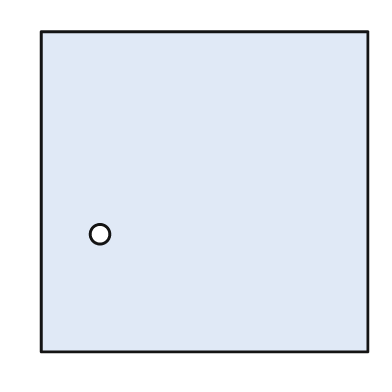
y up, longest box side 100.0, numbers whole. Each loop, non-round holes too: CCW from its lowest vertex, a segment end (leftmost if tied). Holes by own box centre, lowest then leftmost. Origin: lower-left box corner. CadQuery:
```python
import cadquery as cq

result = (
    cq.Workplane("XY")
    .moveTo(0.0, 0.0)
    .lineTo(100.0, 0.0)
    .lineTo(100.0, 98.0)
    .lineTo(0.0, 98.0)
    .close()
    .moveTo(18.0, 36.0)
    .circle(3.0)
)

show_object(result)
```